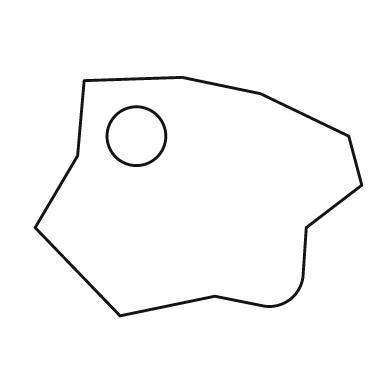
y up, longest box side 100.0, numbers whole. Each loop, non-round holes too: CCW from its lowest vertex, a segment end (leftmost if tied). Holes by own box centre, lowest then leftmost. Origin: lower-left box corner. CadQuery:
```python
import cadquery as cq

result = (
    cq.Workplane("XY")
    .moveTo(26.0, 0.0)
    .lineTo(55.0, 6.0)
    .lineTo(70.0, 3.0)
    .threePointArc((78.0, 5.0), (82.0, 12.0))
    .lineTo(83.0, 27.0)
    .lineTo(100.0, 40.0)
    .lineTo(96.0, 55.0)
    .lineTo(69.0, 68.0)
    .lineTo(45.0, 73.0)
    .lineTo(15.0, 72.0)
    .lineTo(13.0, 49.0)
    .lineTo(0.0, 27.0)
    .close()
    .moveTo(31.0, 55.0)
    .circle(9.0)
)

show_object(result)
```